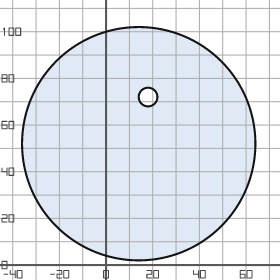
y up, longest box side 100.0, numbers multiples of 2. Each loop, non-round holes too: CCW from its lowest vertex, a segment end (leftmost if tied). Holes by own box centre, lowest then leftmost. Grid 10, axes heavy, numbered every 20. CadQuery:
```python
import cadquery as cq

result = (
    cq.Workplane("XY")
    .moveTo(14.0, 52.0)
    .circle(50.0)
    .moveTo(18.0, 72.0)
    .circle(4.0)
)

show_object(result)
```